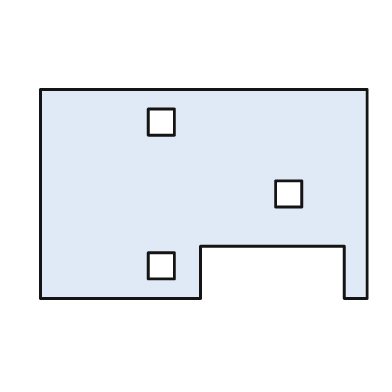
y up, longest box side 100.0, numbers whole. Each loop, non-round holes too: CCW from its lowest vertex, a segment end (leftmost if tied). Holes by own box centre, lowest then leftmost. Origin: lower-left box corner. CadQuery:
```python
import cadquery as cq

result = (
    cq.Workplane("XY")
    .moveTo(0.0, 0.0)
    .lineTo(49.0, 0.0)
    .lineTo(49.0, 16.0)
    .lineTo(93.0, 16.0)
    .lineTo(93.0, 0.0)
    .lineTo(100.0, 0.0)
    .lineTo(100.0, 64.0)
    .lineTo(0.0, 64.0)
    .close()
    .moveTo(33.0, 6.0)
    .lineTo(41.0, 6.0)
    .lineTo(41.0, 14.0)
    .lineTo(33.0, 14.0)
    .close()
    .moveTo(72.0, 28.0)
    .lineTo(80.0, 28.0)
    .lineTo(80.0, 36.0)
    .lineTo(72.0, 36.0)
    .close()
    .moveTo(33.0, 50.0)
    .lineTo(41.0, 50.0)
    .lineTo(41.0, 58.0)
    .lineTo(33.0, 58.0)
    .close()
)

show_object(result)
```